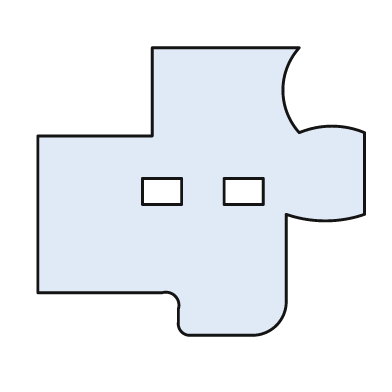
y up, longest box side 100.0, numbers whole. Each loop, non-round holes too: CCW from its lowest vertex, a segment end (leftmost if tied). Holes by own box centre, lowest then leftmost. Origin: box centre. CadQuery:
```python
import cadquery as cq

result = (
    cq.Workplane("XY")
    .moveTo(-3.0, -44.0)
    .lineTo(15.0, -44.0)
    .threePointArc((23.0, -41.0), (26.0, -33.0))
    .lineTo(26.0, -7.0)
    .threePointArc((38.0, -9.0), (50.0, -7.0))
    .lineTo(50.0, 18.0)
    .threePointArc((40.0, 20.0), (30.0, 18.0))
    .threePointArc((25.0, 31.0), (30.0, 44.0))
    .lineTo(-15.0, 44.0)
    .lineTo(-15.0, 17.0)
    .lineTo(-50.0, 17.0)
    .lineTo(-50.0, -31.0)
    .lineTo(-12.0, -31.0)
    .threePointArc((-8.0, -32.0), (-7.0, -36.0))
    .lineTo(-7.0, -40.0)
    .threePointArc((-6.0, -43.0), (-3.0, -44.0))
    .close()
    .moveTo(-18.0, -4.0)
    .lineTo(-6.0, -4.0)
    .lineTo(-6.0, 4.0)
    .lineTo(-18.0, 4.0)
    .close()
    .moveTo(7.0, -4.0)
    .lineTo(19.0, -4.0)
    .lineTo(19.0, 4.0)
    .lineTo(7.0, 4.0)
    .close()
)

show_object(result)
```